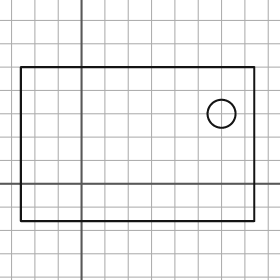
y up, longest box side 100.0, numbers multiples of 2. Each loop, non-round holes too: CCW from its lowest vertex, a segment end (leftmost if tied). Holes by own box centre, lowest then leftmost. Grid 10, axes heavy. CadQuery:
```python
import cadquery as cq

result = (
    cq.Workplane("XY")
    .moveTo(-26.0, -16.0)
    .lineTo(74.0, -16.0)
    .lineTo(74.0, 50.0)
    .lineTo(-26.0, 50.0)
    .close()
    .moveTo(60.0, 30.0)
    .circle(6.0)
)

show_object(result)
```